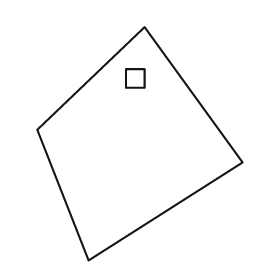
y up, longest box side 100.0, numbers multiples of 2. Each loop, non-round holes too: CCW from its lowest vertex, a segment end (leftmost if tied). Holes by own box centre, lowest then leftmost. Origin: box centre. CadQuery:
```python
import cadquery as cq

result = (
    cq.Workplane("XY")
    .moveTo(-22.0, -50.0)
    .lineTo(44.0, -8.0)
    .lineTo(2.0, 50.0)
    .lineTo(-44.0, 6.0)
    .close()
    .moveTo(-6.0, 24.0)
    .lineTo(2.0, 24.0)
    .lineTo(2.0, 32.0)
    .lineTo(-6.0, 32.0)
    .close()
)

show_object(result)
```